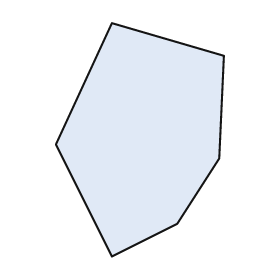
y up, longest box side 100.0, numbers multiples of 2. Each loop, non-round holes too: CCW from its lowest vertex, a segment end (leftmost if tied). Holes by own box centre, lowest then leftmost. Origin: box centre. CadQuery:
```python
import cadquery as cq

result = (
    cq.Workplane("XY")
    .moveTo(-12.0, -50.0)
    .lineTo(16.0, -36.0)
    .lineTo(34.0, -8.0)
    .lineTo(36.0, 36.0)
    .lineTo(-12.0, 50.0)
    .lineTo(-36.0, -2.0)
    .close()
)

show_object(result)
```